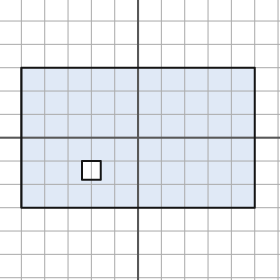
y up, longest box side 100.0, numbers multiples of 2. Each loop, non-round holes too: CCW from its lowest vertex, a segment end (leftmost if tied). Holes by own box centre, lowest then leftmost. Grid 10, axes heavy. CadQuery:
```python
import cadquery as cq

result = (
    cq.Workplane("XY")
    .moveTo(-50.0, -30.0)
    .lineTo(50.0, -30.0)
    .lineTo(50.0, 30.0)
    .lineTo(-50.0, 30.0)
    .close()
    .moveTo(-24.0, -18.0)
    .lineTo(-16.0, -18.0)
    .lineTo(-16.0, -10.0)
    .lineTo(-24.0, -10.0)
    .close()
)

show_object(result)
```